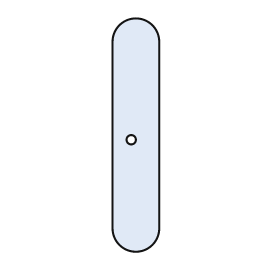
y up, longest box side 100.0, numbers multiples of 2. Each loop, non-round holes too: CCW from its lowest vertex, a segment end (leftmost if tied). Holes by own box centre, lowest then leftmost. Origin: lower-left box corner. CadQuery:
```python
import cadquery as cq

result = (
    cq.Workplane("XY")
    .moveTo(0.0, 10.0)
    .threePointArc((10.0, 0.0), (20.0, 10.0))
    .lineTo(20.0, 90.0)
    .threePointArc((10.0, 100.0), (0.0, 90.0))
    .close()
    .moveTo(8.0, 48.0)
    .circle(2.0)
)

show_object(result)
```